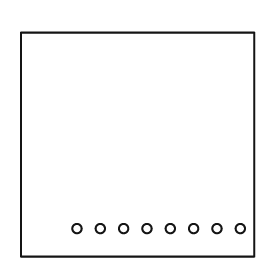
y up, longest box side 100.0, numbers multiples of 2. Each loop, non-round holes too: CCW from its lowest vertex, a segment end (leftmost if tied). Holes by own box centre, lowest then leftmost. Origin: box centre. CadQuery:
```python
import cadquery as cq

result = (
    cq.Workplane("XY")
    .moveTo(-50.0, -48.0)
    .lineTo(50.0, -48.0)
    .lineTo(50.0, 48.0)
    .lineTo(-50.0, 48.0)
    .close()
    .moveTo(-26.0, -36.0)
    .circle(2.0)
    .moveTo(-16.0, -36.0)
    .circle(2.0)
    .moveTo(-6.0, -36.0)
    .circle(2.0)
    .moveTo(4.0, -36.0)
    .circle(2.0)
    .moveTo(14.0, -36.0)
    .circle(2.0)
    .moveTo(24.0, -36.0)
    .circle(2.0)
    .moveTo(34.0, -36.0)
    .circle(2.0)
    .moveTo(44.0, -36.0)
    .circle(2.0)
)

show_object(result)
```